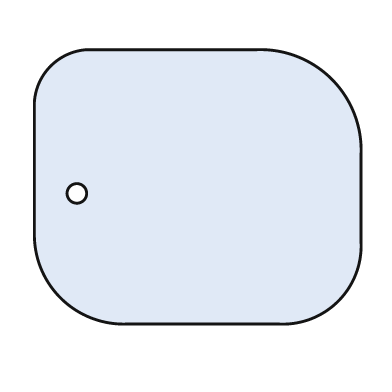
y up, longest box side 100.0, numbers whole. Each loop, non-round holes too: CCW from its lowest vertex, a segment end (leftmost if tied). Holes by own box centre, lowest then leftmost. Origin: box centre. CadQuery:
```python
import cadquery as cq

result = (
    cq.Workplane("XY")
    .moveTo(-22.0, -42.0)
    .lineTo(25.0, -42.0)
    .threePointArc((43.0, -35.0), (50.0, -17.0))
    .lineTo(50.0, 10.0)
    .threePointArc((41.0, 33.0), (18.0, 42.0))
    .lineTo(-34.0, 42.0)
    .threePointArc((-45.0, 37.0), (-50.0, 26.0))
    .lineTo(-50.0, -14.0)
    .threePointArc((-42.0, -34.0), (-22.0, -42.0))
    .close()
    .moveTo(-37.0, -2.0)
    .circle(3.0)
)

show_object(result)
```